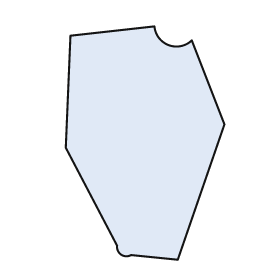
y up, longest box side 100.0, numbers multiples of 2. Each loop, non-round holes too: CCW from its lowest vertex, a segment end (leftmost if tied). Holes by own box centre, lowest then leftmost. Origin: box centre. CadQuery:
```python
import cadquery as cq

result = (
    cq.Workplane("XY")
    .moveTo(14.0, -50.0)
    .lineTo(34.0, 8.0)
    .lineTo(20.0, 44.0)
    .threePointArc((10.0, 42.0), (4.0, 50.0))
    .lineTo(-32.0, 46.0)
    .lineTo(-34.0, -2.0)
    .lineTo(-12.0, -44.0)
    .threePointArc((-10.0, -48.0), (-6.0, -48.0))
    .close()
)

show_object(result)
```